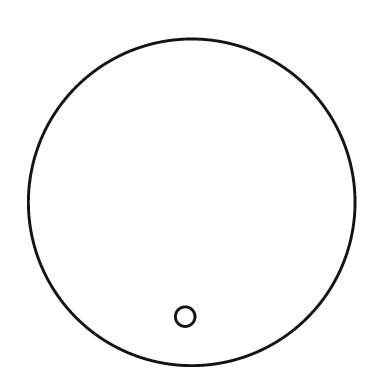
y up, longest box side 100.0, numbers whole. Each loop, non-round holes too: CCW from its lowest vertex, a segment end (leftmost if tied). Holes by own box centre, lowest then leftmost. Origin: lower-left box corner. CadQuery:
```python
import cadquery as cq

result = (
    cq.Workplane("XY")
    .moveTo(50.0, 50.0)
    .circle(50.0)
    .moveTo(48.0, 15.0)
    .circle(3.0)
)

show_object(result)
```